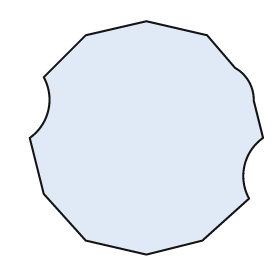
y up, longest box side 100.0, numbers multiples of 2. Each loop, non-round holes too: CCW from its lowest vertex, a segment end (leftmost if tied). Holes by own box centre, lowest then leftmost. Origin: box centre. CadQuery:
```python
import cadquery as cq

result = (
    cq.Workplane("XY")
    .moveTo(0.0, -50.0)
    .lineTo(24.0, -44.0)
    .lineTo(44.0, -26.0)
    .threePointArc((42.0, -12.0), (50.0, 0.0))
    .lineTo(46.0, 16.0)
    .threePointArc((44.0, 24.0), (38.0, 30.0))
    .lineTo(26.0, 44.0)
    .lineTo(0.0, 50.0)
    .lineTo(-26.0, 44.0)
    .lineTo(-44.0, 26.0)
    .threePointArc((-42.0, 12.0), (-50.0, 0.0))
    .lineTo(-44.0, -24.0)
    .lineTo(-26.0, -44.0)
    .close()
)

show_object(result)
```